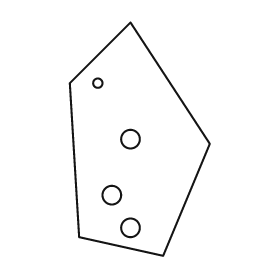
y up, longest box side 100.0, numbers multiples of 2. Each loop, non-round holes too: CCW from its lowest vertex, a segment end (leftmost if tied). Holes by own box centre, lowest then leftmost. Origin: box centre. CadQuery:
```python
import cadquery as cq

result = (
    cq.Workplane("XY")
    .moveTo(10.0, -50.0)
    .lineTo(30.0, -2.0)
    .lineTo(-4.0, 50.0)
    .lineTo(-30.0, 24.0)
    .lineTo(-26.0, -42.0)
    .close()
    .moveTo(-4.0, -38.0)
    .circle(4.0)
    .moveTo(-12.0, -24.0)
    .circle(4.0)
    .moveTo(-4.0, 0.0)
    .circle(4.0)
    .moveTo(-18.0, 24.0)
    .circle(2.0)
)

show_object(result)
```